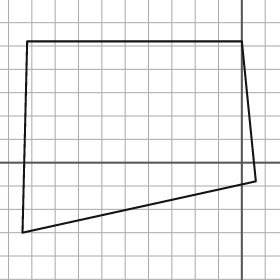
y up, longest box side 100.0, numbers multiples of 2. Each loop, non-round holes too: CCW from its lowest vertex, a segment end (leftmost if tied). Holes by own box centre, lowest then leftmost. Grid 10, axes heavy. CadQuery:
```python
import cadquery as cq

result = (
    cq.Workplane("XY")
    .moveTo(-94.0, -30.0)
    .lineTo(6.0, -8.0)
    .lineTo(0.0, 52.0)
    .lineTo(-92.0, 52.0)
    .close()
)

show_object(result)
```